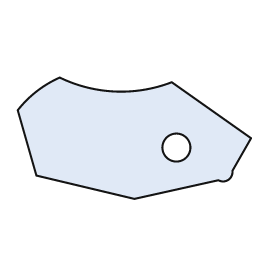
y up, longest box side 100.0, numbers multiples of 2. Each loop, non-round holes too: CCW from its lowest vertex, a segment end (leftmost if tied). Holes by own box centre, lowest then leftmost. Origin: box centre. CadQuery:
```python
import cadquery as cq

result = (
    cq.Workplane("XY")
    .moveTo(0.0, -26.0)
    .lineTo(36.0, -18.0)
    .threePointArc((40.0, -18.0), (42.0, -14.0))
    .lineTo(50.0, 0.0)
    .lineTo(16.0, 24.0)
    .threePointArc((-8.0, 20.0), (-32.0, 26.0))
    .threePointArc((-42.0, 20.0), (-50.0, 12.0))
    .lineTo(-42.0, -16.0)
    .close()
    .moveTo(18.0, -4.0)
    .circle(6.0)
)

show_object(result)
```